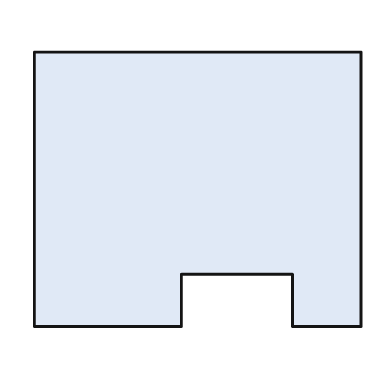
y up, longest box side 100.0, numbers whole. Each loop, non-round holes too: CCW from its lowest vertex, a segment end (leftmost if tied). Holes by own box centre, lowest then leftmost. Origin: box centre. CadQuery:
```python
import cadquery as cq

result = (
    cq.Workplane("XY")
    .moveTo(-50.0, -42.0)
    .lineTo(-5.0, -42.0)
    .lineTo(-5.0, -26.0)
    .lineTo(29.0, -26.0)
    .lineTo(29.0, -42.0)
    .lineTo(50.0, -42.0)
    .lineTo(50.0, 42.0)
    .lineTo(-50.0, 42.0)
    .close()
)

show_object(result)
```